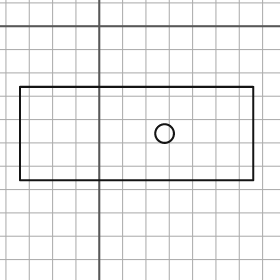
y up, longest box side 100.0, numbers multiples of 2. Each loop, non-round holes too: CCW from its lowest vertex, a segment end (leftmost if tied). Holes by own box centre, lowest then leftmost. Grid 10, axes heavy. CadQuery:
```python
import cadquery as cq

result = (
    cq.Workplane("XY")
    .moveTo(-34.0, -66.0)
    .lineTo(66.0, -66.0)
    .lineTo(66.0, -26.0)
    .lineTo(-34.0, -26.0)
    .close()
    .moveTo(28.0, -46.0)
    .circle(4.0)
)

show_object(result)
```